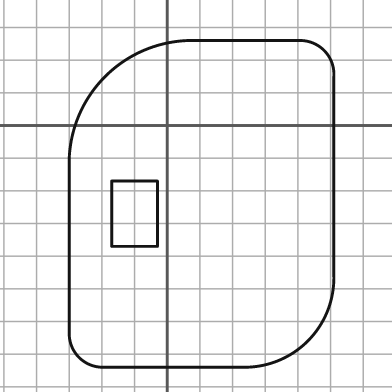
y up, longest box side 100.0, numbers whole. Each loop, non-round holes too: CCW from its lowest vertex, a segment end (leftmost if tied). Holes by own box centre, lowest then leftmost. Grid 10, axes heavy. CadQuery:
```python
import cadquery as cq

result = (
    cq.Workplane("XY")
    .moveTo(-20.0, -74.0)
    .lineTo(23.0, -74.0)
    .threePointArc((43.0, -66.0), (51.0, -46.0))
    .lineTo(51.0, 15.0)
    .threePointArc((48.0, 23.0), (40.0, 26.0))
    .lineTo(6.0, 26.0)
    .threePointArc((-19.0, 15.0), (-30.0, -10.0))
    .lineTo(-30.0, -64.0)
    .threePointArc((-27.0, -71.0), (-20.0, -74.0))
    .close()
    .moveTo(-17.0, -37.0)
    .lineTo(-3.0, -37.0)
    .lineTo(-3.0, -17.0)
    .lineTo(-17.0, -17.0)
    .close()
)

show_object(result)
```